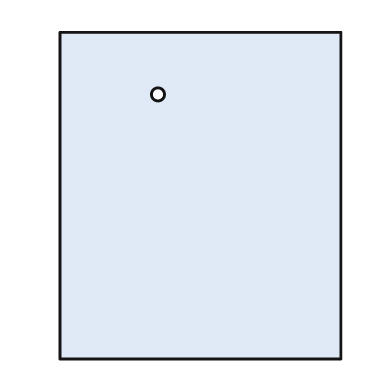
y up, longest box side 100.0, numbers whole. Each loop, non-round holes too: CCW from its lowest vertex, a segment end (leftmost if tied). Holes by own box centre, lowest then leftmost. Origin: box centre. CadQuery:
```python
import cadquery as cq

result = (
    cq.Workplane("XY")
    .moveTo(-43.0, -50.0)
    .lineTo(43.0, -50.0)
    .lineTo(43.0, 50.0)
    .lineTo(-43.0, 50.0)
    .close()
    .moveTo(-13.0, 31.0)
    .circle(2.0)
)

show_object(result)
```